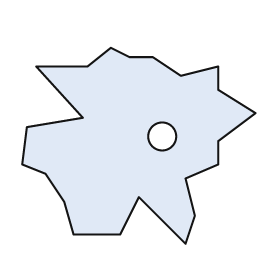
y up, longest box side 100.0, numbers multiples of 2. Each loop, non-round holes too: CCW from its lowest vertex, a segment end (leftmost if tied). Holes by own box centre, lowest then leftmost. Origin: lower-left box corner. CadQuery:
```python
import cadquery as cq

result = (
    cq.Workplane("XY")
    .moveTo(70.0, 0.0)
    .lineTo(74.0, 12.0)
    .lineTo(70.0, 28.0)
    .lineTo(84.0, 34.0)
    .lineTo(84.0, 44.0)
    .lineTo(100.0, 56.0)
    .lineTo(84.0, 66.0)
    .lineTo(84.0, 76.0)
    .lineTo(68.0, 72.0)
    .lineTo(56.0, 80.0)
    .lineTo(46.0, 80.0)
    .lineTo(38.0, 84.0)
    .lineTo(28.0, 76.0)
    .lineTo(6.0, 76.0)
    .lineTo(26.0, 54.0)
    .lineTo(2.0, 50.0)
    .lineTo(0.0, 34.0)
    .lineTo(10.0, 30.0)
    .lineTo(18.0, 18.0)
    .lineTo(22.0, 4.0)
    .lineTo(42.0, 4.0)
    .lineTo(50.0, 20.0)
    .close()
    .moveTo(60.0, 46.0)
    .circle(6.0)
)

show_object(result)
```